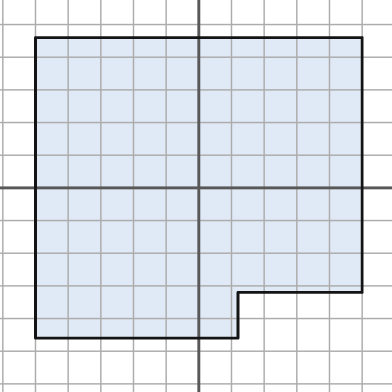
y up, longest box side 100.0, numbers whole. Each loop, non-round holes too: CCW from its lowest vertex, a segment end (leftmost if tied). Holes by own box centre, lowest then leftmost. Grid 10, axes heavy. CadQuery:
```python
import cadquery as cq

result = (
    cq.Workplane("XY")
    .moveTo(-50.0, -46.0)
    .lineTo(12.0, -46.0)
    .lineTo(12.0, -32.0)
    .lineTo(50.0, -32.0)
    .lineTo(50.0, 46.0)
    .lineTo(-50.0, 46.0)
    .close()
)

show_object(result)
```